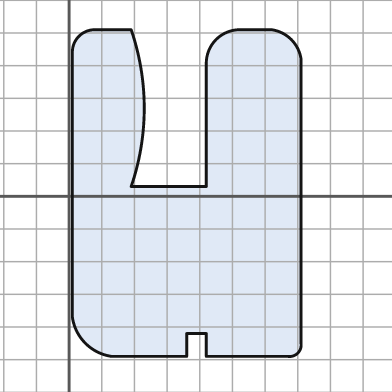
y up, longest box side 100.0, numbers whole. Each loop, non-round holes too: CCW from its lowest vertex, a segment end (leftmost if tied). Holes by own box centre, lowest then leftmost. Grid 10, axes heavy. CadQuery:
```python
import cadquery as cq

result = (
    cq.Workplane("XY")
    .moveTo(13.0, -49.0)
    .lineTo(36.0, -49.0)
    .lineTo(36.0, -42.0)
    .lineTo(42.0, -42.0)
    .lineTo(42.0, -49.0)
    .lineTo(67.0, -49.0)
    .threePointArc((70.0, -48.0), (71.0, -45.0))
    .lineTo(71.0, 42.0)
    .threePointArc((68.0, 48.0), (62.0, 51.0))
    .lineTo(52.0, 51.0)
    .threePointArc((45.0, 48.0), (42.0, 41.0))
    .lineTo(42.0, 3.0)
    .lineTo(19.0, 3.0)
    .threePointArc((23.0, 27.0), (19.0, 51.0))
    .lineTo(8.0, 51.0)
    .threePointArc((3.0, 49.0), (1.0, 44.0))
    .lineTo(1.0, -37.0)
    .threePointArc((5.0, -45.0), (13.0, -49.0))
    .close()
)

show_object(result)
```